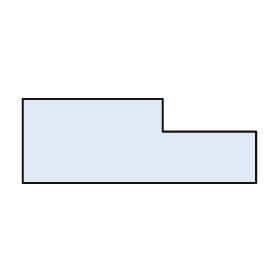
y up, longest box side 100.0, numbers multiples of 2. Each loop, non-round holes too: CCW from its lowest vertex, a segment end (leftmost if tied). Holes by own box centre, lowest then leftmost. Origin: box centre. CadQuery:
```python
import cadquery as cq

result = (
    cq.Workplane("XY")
    .moveTo(-50.0, -18.0)
    .lineTo(50.0, -18.0)
    .lineTo(50.0, 4.0)
    .lineTo(10.0, 4.0)
    .lineTo(10.0, 18.0)
    .lineTo(-50.0, 18.0)
    .close()
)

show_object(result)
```